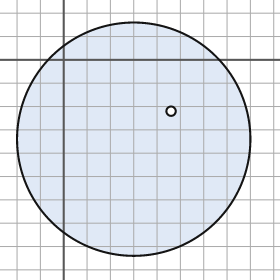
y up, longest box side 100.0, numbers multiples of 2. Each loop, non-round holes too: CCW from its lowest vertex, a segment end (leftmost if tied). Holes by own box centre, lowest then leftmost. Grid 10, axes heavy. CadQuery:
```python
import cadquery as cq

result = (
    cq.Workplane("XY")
    .moveTo(30.0, -34.0)
    .circle(50.0)
    .moveTo(46.0, -22.0)
    .circle(2.0)
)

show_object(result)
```